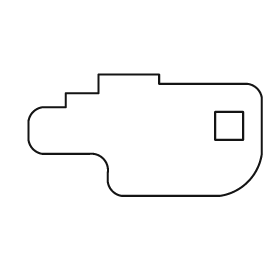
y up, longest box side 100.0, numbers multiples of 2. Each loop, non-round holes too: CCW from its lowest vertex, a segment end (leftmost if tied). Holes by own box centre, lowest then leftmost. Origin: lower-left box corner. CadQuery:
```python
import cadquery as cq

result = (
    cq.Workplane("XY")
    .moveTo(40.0, 0.0)
    .lineTo(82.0, 0.0)
    .threePointArc((94.0, 6.0), (100.0, 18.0))
    .lineTo(100.0, 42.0)
    .threePointArc((98.0, 46.0), (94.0, 48.0))
    .lineTo(56.0, 48.0)
    .lineTo(56.0, 52.0)
    .lineTo(30.0, 52.0)
    .lineTo(30.0, 44.0)
    .lineTo(16.0, 44.0)
    .lineTo(16.0, 38.0)
    .lineTo(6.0, 38.0)
    .threePointArc((2.0, 36.0), (0.0, 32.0))
    .lineTo(0.0, 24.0)
    .threePointArc((2.0, 20.0), (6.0, 18.0))
    .lineTo(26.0, 18.0)
    .threePointArc((32.0, 16.0), (34.0, 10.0))
    .lineTo(34.0, 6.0)
    .threePointArc((36.0, 2.0), (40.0, 0.0))
    .close()
    .moveTo(80.0, 24.0)
    .lineTo(92.0, 24.0)
    .lineTo(92.0, 36.0)
    .lineTo(80.0, 36.0)
    .close()
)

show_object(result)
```